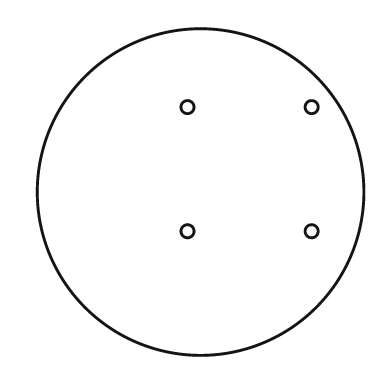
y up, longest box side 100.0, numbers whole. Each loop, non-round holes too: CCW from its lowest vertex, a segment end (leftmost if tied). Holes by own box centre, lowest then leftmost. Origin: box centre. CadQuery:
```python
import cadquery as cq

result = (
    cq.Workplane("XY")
    .moveTo(0.0, 0.0)
    .circle(50.0)
    .moveTo(-4.0, -12.0)
    .circle(2.0)
    .moveTo(34.0, -12.0)
    .circle(2.0)
    .moveTo(-4.0, 26.0)
    .circle(2.0)
    .moveTo(34.0, 26.0)
    .circle(2.0)
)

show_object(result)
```